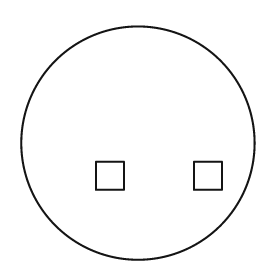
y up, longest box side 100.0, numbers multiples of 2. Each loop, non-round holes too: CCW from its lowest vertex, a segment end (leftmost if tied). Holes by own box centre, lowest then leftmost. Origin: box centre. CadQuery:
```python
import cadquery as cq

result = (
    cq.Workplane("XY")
    .moveTo(0.0, 0.0)
    .circle(50.0)
    .moveTo(-18.0, -20.0)
    .lineTo(-6.0, -20.0)
    .lineTo(-6.0, -8.0)
    .lineTo(-18.0, -8.0)
    .close()
    .moveTo(24.0, -20.0)
    .lineTo(36.0, -20.0)
    .lineTo(36.0, -8.0)
    .lineTo(24.0, -8.0)
    .close()
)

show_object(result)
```